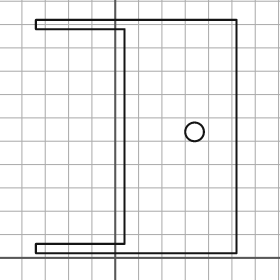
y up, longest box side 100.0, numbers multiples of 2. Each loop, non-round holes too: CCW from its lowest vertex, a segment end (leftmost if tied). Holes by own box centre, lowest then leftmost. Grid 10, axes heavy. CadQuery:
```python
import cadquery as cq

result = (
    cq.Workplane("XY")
    .moveTo(-34.0, 2.0)
    .lineTo(52.0, 2.0)
    .lineTo(52.0, 102.0)
    .lineTo(-34.0, 102.0)
    .lineTo(-34.0, 98.0)
    .lineTo(4.0, 98.0)
    .lineTo(4.0, 6.0)
    .lineTo(-34.0, 6.0)
    .close()
    .moveTo(34.0, 54.0)
    .circle(4.0)
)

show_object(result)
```